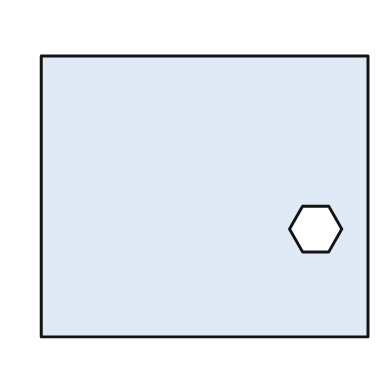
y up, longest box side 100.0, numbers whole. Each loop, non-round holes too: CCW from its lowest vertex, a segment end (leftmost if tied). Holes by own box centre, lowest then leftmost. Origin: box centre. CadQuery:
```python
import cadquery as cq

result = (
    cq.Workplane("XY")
    .moveTo(-50.0, -43.0)
    .lineTo(50.0, -43.0)
    .lineTo(50.0, 43.0)
    .lineTo(-50.0, 43.0)
    .close()
    .moveTo(30.0, -17.0)
    .lineTo(38.0, -17.0)
    .lineTo(42.0, -10.0)
    .lineTo(38.0, -3.0)
    .lineTo(30.0, -3.0)
    .lineTo(26.0, -10.0)
    .close()
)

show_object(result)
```